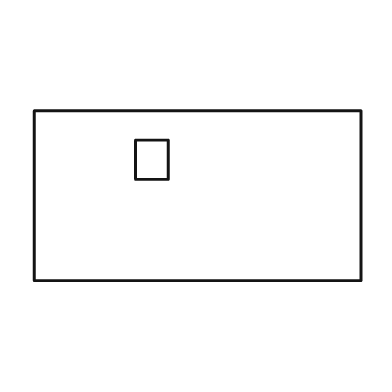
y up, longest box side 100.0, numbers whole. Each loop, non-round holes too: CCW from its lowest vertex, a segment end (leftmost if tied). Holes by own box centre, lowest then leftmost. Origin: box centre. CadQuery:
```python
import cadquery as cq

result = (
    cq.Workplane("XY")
    .moveTo(-50.0, -26.0)
    .lineTo(50.0, -26.0)
    .lineTo(50.0, 26.0)
    .lineTo(-50.0, 26.0)
    .close()
    .moveTo(-19.0, 5.0)
    .lineTo(-9.0, 5.0)
    .lineTo(-9.0, 17.0)
    .lineTo(-19.0, 17.0)
    .close()
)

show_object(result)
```